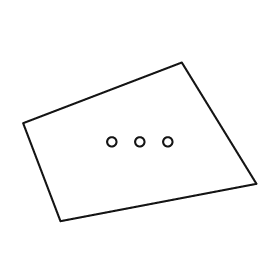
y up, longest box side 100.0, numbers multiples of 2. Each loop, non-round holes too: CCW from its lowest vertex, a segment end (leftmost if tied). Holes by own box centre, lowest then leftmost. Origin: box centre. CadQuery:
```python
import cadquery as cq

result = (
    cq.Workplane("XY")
    .moveTo(-34.0, -34.0)
    .lineTo(50.0, -18.0)
    .lineTo(18.0, 34.0)
    .lineTo(-50.0, 8.0)
    .close()
    .moveTo(-12.0, 0.0)
    .circle(2.0)
    .moveTo(0.0, 0.0)
    .circle(2.0)
    .moveTo(12.0, 0.0)
    .circle(2.0)
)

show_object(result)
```